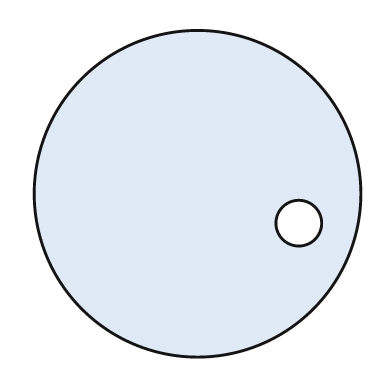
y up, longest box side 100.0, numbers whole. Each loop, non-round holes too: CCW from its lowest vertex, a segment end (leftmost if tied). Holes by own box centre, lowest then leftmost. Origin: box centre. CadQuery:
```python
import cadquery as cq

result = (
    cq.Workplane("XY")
    .moveTo(0.0, 0.0)
    .circle(50.0)
    .moveTo(31.0, -9.0)
    .circle(7.0)
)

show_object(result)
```